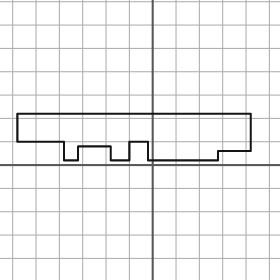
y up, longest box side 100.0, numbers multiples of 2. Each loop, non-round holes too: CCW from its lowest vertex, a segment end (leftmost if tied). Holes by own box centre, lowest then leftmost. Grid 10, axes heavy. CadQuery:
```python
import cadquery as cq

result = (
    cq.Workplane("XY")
    .moveTo(-38.0, 2.0)
    .lineTo(-32.0, 2.0)
    .lineTo(-32.0, 8.0)
    .lineTo(-18.0, 8.0)
    .lineTo(-18.0, 2.0)
    .lineTo(-10.0, 2.0)
    .lineTo(-10.0, 10.0)
    .lineTo(-2.0, 10.0)
    .lineTo(-2.0, 2.0)
    .lineTo(28.0, 2.0)
    .lineTo(28.0, 6.0)
    .lineTo(42.0, 6.0)
    .lineTo(42.0, 22.0)
    .lineTo(-58.0, 22.0)
    .lineTo(-58.0, 10.0)
    .lineTo(-38.0, 10.0)
    .close()
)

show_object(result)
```